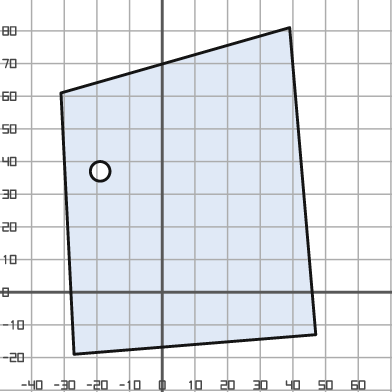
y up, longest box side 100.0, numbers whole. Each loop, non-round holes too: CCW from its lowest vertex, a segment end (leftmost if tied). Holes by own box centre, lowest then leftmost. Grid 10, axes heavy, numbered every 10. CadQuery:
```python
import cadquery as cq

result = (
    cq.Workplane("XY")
    .moveTo(-27.0, -19.0)
    .lineTo(47.0, -13.0)
    .lineTo(39.0, 81.0)
    .lineTo(-31.0, 61.0)
    .close()
    .moveTo(-19.0, 37.0)
    .circle(3.0)
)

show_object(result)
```